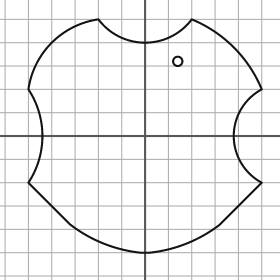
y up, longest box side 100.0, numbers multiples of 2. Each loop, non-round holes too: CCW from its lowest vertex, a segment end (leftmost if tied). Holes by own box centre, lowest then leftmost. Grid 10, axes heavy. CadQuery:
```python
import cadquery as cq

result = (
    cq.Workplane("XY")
    .moveTo(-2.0, -50.0)
    .lineTo(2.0, -50.0)
    .threePointArc((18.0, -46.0), (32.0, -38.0))
    .lineTo(50.0, -20.0)
    .threePointArc((38.0, 0.0), (50.0, 20.0))
    .threePointArc((38.0, 38.0), (20.0, 50.0))
    .threePointArc((0.0, 40.0), (-20.0, 50.0))
    .threePointArc((-40.0, 40.0), (-50.0, 20.0))
    .threePointArc((-44.0, 0.0), (-50.0, -20.0))
    .lineTo(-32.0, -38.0)
    .threePointArc((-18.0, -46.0), (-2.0, -50.0))
    .close()
    .moveTo(14.0, 32.0)
    .circle(2.0)
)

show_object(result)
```